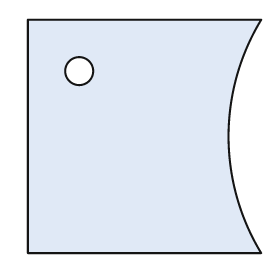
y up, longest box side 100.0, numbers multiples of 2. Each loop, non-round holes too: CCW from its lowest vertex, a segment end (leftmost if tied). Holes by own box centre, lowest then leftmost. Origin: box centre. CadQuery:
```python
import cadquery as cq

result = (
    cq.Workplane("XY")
    .moveTo(-50.0, -50.0)
    .lineTo(50.0, -50.0)
    .threePointArc((36.0, 0.0), (50.0, 50.0))
    .lineTo(-50.0, 50.0)
    .close()
    .moveTo(-28.0, 28.0)
    .circle(6.0)
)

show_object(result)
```